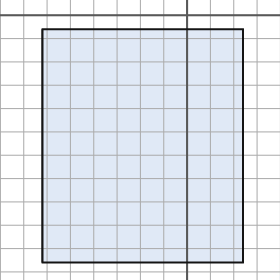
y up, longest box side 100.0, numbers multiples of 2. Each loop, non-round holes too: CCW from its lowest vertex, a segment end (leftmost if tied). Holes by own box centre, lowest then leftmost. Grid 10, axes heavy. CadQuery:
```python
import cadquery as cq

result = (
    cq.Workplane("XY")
    .moveTo(-62.0, -106.0)
    .lineTo(24.0, -106.0)
    .lineTo(24.0, -6.0)
    .lineTo(-62.0, -6.0)
    .close()
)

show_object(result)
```